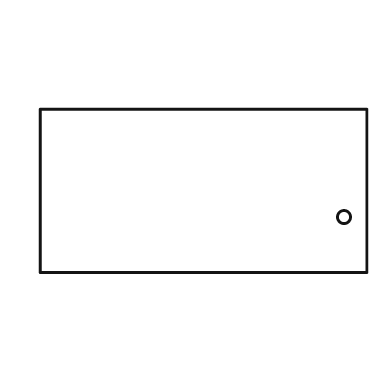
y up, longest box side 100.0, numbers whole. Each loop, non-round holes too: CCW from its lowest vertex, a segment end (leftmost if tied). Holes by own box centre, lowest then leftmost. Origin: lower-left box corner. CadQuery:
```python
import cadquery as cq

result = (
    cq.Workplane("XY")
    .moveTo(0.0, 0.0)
    .lineTo(100.0, 0.0)
    .lineTo(100.0, 50.0)
    .lineTo(0.0, 50.0)
    .close()
    .moveTo(93.0, 17.0)
    .circle(2.0)
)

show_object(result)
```